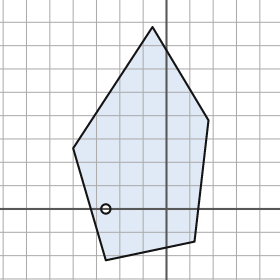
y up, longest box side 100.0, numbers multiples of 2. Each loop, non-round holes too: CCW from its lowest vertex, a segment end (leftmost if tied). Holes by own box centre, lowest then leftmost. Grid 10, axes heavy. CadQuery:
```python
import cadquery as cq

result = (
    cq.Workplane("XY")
    .moveTo(-26.0, -22.0)
    .lineTo(12.0, -14.0)
    .lineTo(18.0, 38.0)
    .lineTo(-6.0, 78.0)
    .lineTo(-40.0, 26.0)
    .close()
    .moveTo(-26.0, 0.0)
    .circle(2.0)
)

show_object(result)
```